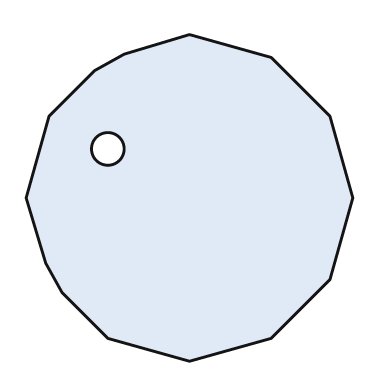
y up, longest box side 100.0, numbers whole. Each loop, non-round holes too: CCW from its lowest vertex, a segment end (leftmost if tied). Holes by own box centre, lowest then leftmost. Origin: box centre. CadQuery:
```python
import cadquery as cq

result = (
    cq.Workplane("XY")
    .moveTo(0.0, -50.0)
    .lineTo(25.0, -43.0)
    .lineTo(43.0, -25.0)
    .lineTo(50.0, 0.0)
    .lineTo(43.0, 25.0)
    .lineTo(25.0, 43.0)
    .lineTo(0.0, 50.0)
    .lineTo(-20.0, 44.0)
    .lineTo(-29.0, 39.0)
    .lineTo(-43.0, 25.0)
    .lineTo(-50.0, 0.0)
    .lineTo(-44.0, -20.0)
    .lineTo(-39.0, -29.0)
    .lineTo(-25.0, -43.0)
    .close()
    .moveTo(-25.0, 15.0)
    .circle(5.0)
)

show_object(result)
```